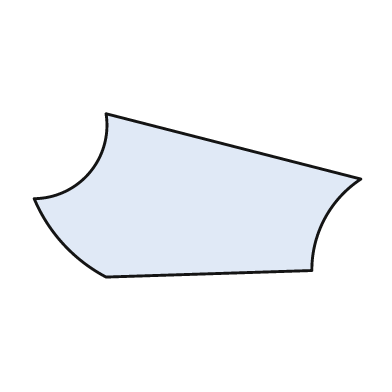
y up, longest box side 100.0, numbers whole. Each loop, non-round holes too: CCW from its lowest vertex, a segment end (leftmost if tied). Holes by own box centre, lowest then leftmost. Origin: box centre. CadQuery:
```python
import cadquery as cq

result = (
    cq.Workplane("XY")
    .moveTo(-28.0, -25.0)
    .lineTo(35.0, -23.0)
    .threePointArc((39.0, -7.0), (50.0, 5.0))
    .lineTo(-28.0, 25.0)
    .threePointArc((-33.0, 7.0), (-50.0, -1.0))
    .threePointArc((-41.0, -15.0), (-28.0, -25.0))
    .close()
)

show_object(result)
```